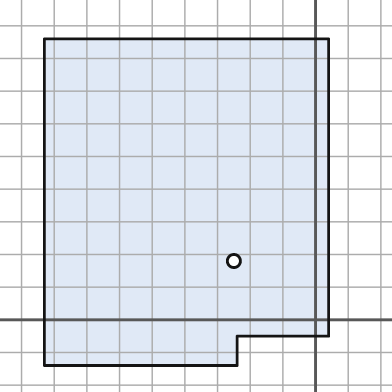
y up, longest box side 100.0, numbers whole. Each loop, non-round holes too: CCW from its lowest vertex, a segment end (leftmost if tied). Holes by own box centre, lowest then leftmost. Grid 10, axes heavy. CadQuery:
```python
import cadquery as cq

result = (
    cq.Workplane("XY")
    .moveTo(-83.0, -14.0)
    .lineTo(-24.0, -14.0)
    .lineTo(-24.0, -5.0)
    .lineTo(4.0, -5.0)
    .lineTo(4.0, 86.0)
    .lineTo(-83.0, 86.0)
    .close()
    .moveTo(-25.0, 18.0)
    .circle(2.0)
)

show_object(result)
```